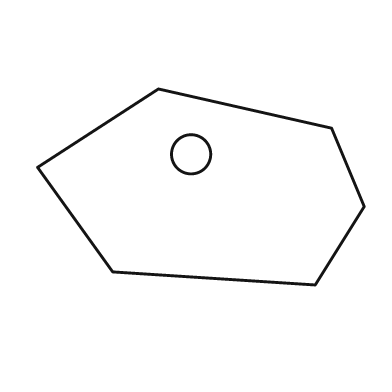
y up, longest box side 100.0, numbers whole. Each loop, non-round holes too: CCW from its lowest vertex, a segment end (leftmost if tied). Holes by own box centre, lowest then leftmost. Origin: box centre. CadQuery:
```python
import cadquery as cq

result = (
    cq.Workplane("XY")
    .moveTo(35.0, -30.0)
    .lineTo(50.0, -6.0)
    .lineTo(40.0, 18.0)
    .lineTo(-13.0, 30.0)
    .lineTo(-50.0, 6.0)
    .lineTo(-27.0, -26.0)
    .close()
    .moveTo(-3.0, 10.0)
    .circle(6.0)
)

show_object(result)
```